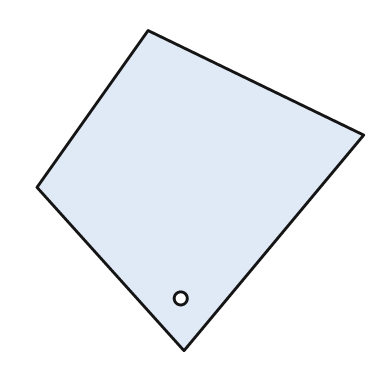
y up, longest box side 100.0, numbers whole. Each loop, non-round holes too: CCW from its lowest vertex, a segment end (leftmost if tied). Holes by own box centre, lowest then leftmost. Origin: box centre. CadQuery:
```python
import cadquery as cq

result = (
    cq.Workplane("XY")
    .moveTo(-5.0, -49.0)
    .lineTo(50.0, 17.0)
    .lineTo(-16.0, 49.0)
    .lineTo(-50.0, 1.0)
    .close()
    .moveTo(-6.0, -33.0)
    .circle(2.0)
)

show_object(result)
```